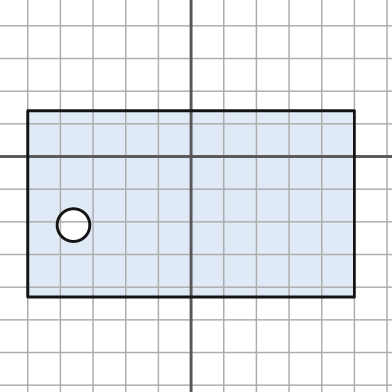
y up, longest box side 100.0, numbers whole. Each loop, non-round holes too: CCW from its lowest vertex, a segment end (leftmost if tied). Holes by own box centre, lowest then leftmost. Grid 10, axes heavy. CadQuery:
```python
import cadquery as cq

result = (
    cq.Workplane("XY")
    .moveTo(-50.0, -43.0)
    .lineTo(50.0, -43.0)
    .lineTo(50.0, 14.0)
    .lineTo(-50.0, 14.0)
    .close()
    .moveTo(-36.0, -21.0)
    .circle(5.0)
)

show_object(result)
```